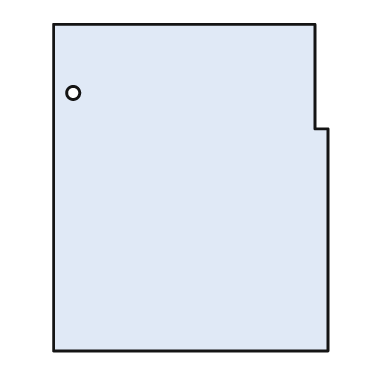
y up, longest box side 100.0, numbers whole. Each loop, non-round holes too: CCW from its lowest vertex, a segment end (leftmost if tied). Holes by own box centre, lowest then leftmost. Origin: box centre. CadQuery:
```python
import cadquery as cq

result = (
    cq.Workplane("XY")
    .moveTo(-42.0, -50.0)
    .lineTo(42.0, -50.0)
    .lineTo(42.0, 18.0)
    .lineTo(38.0, 18.0)
    .lineTo(38.0, 50.0)
    .lineTo(-42.0, 50.0)
    .close()
    .moveTo(-36.0, 29.0)
    .circle(2.0)
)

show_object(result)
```